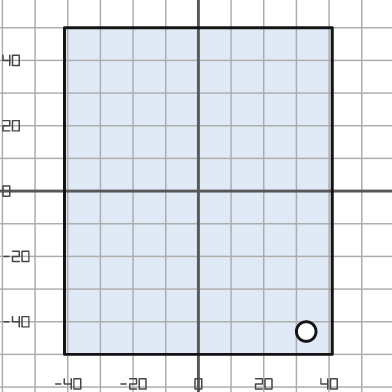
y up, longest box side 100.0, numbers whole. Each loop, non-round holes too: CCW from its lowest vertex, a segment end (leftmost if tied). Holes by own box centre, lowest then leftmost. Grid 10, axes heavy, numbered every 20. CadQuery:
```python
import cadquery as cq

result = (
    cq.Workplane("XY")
    .moveTo(-41.0, -50.0)
    .lineTo(41.0, -50.0)
    .lineTo(41.0, 50.0)
    .lineTo(-41.0, 50.0)
    .close()
    .moveTo(33.0, -43.0)
    .circle(3.0)
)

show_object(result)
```